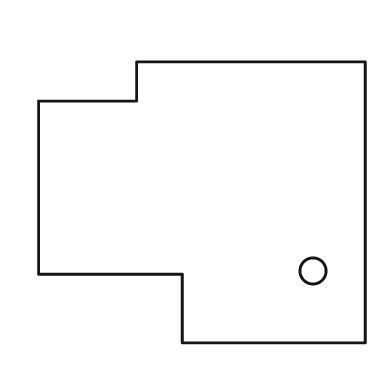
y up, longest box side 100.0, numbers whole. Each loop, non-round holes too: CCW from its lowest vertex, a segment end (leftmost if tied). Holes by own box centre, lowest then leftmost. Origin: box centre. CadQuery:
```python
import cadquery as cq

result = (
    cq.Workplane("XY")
    .moveTo(-6.0, -43.0)
    .lineTo(50.0, -43.0)
    .lineTo(50.0, 43.0)
    .lineTo(-20.0, 43.0)
    .lineTo(-20.0, 31.0)
    .lineTo(-50.0, 31.0)
    .lineTo(-50.0, -22.0)
    .lineTo(-6.0, -22.0)
    .close()
    .moveTo(34.0, -21.0)
    .circle(4.0)
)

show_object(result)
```